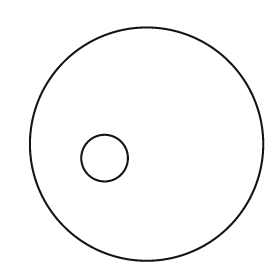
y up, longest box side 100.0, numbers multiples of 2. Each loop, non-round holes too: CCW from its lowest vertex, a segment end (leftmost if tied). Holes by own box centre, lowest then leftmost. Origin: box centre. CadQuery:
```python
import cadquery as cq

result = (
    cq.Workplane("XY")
    .moveTo(0.0, 0.0)
    .circle(50.0)
    .moveTo(-18.0, -6.0)
    .circle(10.0)
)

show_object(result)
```